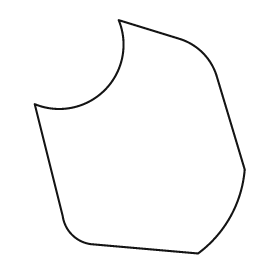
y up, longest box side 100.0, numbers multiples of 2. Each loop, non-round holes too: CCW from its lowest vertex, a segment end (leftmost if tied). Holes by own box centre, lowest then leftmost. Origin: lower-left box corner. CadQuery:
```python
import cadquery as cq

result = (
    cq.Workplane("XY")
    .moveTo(70.0, 0.0)
    .threePointArc((84.0, 16.0), (90.0, 36.0))
    .lineTo(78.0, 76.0)
    .threePointArc((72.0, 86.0), (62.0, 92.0))
    .lineTo(36.0, 100.0)
    .threePointArc((30.0, 70.0), (0.0, 64.0))
    .lineTo(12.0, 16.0)
    .threePointArc((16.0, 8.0), (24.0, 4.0))
    .close()
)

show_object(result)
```